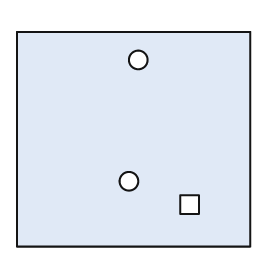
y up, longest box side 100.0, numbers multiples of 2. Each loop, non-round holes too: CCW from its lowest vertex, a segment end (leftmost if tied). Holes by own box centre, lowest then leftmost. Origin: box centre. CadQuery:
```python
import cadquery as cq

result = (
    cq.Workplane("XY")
    .moveTo(-50.0, -46.0)
    .lineTo(50.0, -46.0)
    .lineTo(50.0, 46.0)
    .lineTo(-50.0, 46.0)
    .close()
    .moveTo(20.0, -32.0)
    .lineTo(28.0, -32.0)
    .lineTo(28.0, -24.0)
    .lineTo(20.0, -24.0)
    .close()
    .moveTo(-2.0, -18.0)
    .circle(4.0)
    .moveTo(2.0, 34.0)
    .circle(4.0)
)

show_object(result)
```